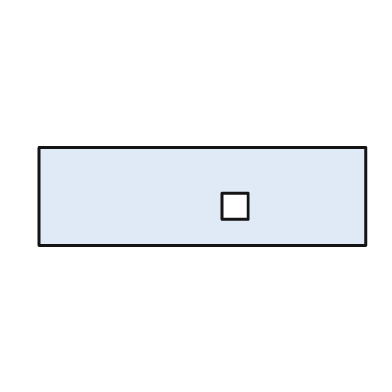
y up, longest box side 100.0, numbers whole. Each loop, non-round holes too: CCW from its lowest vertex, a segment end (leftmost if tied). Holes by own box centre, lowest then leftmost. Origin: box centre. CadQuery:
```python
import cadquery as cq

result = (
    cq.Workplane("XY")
    .moveTo(-50.0, -15.0)
    .lineTo(50.0, -15.0)
    .lineTo(50.0, 15.0)
    .lineTo(-50.0, 15.0)
    .close()
    .moveTo(6.0, -7.0)
    .lineTo(14.0, -7.0)
    .lineTo(14.0, 1.0)
    .lineTo(6.0, 1.0)
    .close()
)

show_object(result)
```